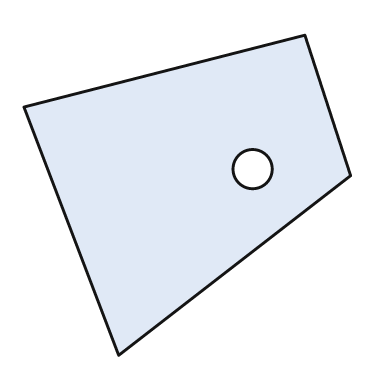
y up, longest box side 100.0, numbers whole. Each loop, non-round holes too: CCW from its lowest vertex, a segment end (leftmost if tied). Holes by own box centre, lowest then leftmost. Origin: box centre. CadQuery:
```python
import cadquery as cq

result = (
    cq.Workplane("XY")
    .moveTo(-21.0, -49.0)
    .lineTo(50.0, 6.0)
    .lineTo(36.0, 49.0)
    .lineTo(-50.0, 27.0)
    .close()
    .moveTo(20.0, 8.0)
    .circle(6.0)
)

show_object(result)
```